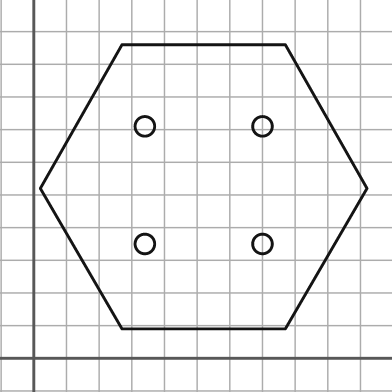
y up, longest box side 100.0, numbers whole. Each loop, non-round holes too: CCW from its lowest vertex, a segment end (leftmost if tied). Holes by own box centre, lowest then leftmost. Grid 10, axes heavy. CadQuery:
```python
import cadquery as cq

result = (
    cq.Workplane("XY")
    .moveTo(27.0, 9.0)
    .lineTo(77.0, 9.0)
    .lineTo(102.0, 52.0)
    .lineTo(77.0, 96.0)
    .lineTo(27.0, 96.0)
    .lineTo(2.0, 52.0)
    .close()
    .moveTo(34.0, 35.0)
    .circle(3.0)
    .moveTo(70.0, 35.0)
    .circle(3.0)
    .moveTo(34.0, 71.0)
    .circle(3.0)
    .moveTo(70.0, 71.0)
    .circle(3.0)
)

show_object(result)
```